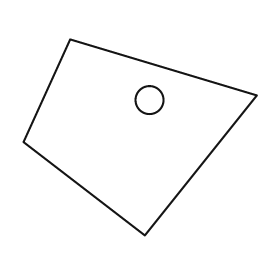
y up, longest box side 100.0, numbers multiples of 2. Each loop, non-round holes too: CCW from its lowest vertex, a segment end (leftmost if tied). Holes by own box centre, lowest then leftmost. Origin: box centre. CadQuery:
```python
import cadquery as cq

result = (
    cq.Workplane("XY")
    .moveTo(2.0, -42.0)
    .lineTo(50.0, 18.0)
    .lineTo(-30.0, 42.0)
    .lineTo(-50.0, -2.0)
    .close()
    .moveTo(4.0, 16.0)
    .circle(6.0)
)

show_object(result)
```